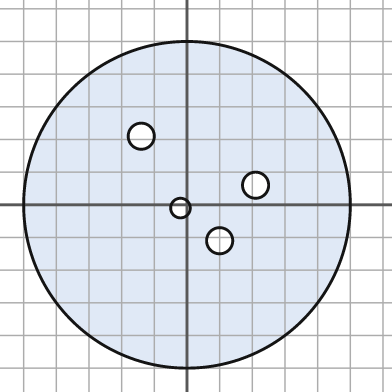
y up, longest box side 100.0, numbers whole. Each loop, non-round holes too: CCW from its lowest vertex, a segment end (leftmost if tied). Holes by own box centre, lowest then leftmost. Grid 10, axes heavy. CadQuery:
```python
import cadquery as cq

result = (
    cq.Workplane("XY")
    .moveTo(0.0, 0.0)
    .circle(50.0)
    .moveTo(10.0, -11.0)
    .circle(4.0)
    .moveTo(-2.0, -1.0)
    .circle(3.0)
    .moveTo(21.0, 6.0)
    .circle(4.0)
    .moveTo(-14.0, 21.0)
    .circle(4.0)
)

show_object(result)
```